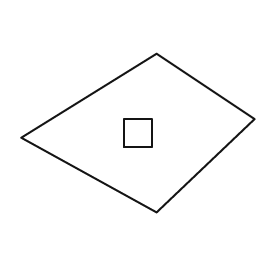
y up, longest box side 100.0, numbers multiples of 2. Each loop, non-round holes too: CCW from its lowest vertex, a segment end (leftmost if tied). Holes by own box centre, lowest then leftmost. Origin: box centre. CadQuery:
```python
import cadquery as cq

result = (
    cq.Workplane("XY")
    .moveTo(8.0, -34.0)
    .lineTo(50.0, 6.0)
    .lineTo(8.0, 34.0)
    .lineTo(-50.0, -2.0)
    .close()
    .moveTo(-6.0, -6.0)
    .lineTo(6.0, -6.0)
    .lineTo(6.0, 6.0)
    .lineTo(-6.0, 6.0)
    .close()
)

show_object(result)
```